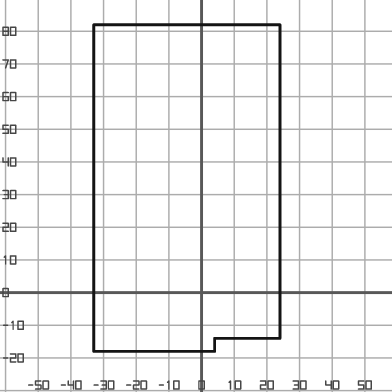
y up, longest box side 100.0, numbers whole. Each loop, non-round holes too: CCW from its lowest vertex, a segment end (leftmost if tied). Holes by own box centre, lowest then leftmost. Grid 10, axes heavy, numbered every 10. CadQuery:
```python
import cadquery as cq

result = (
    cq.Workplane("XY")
    .moveTo(-33.0, -18.0)
    .lineTo(4.0, -18.0)
    .lineTo(4.0, -14.0)
    .lineTo(24.0, -14.0)
    .lineTo(24.0, 82.0)
    .lineTo(-33.0, 82.0)
    .close()
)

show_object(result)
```